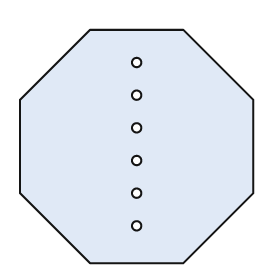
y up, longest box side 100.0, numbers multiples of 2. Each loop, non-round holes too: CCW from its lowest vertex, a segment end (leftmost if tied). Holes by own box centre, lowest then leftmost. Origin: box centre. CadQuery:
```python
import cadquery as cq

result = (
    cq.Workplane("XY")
    .moveTo(-20.0, -50.0)
    .lineTo(20.0, -50.0)
    .lineTo(50.0, -20.0)
    .lineTo(50.0, 20.0)
    .lineTo(20.0, 50.0)
    .lineTo(-20.0, 50.0)
    .lineTo(-50.0, 20.0)
    .lineTo(-50.0, -20.0)
    .close()
    .moveTo(0.0, -34.0)
    .circle(2.0)
    .moveTo(0.0, -20.0)
    .circle(2.0)
    .moveTo(0.0, -6.0)
    .circle(2.0)
    .moveTo(0.0, 8.0)
    .circle(2.0)
    .moveTo(0.0, 22.0)
    .circle(2.0)
    .moveTo(0.0, 36.0)
    .circle(2.0)
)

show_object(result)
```